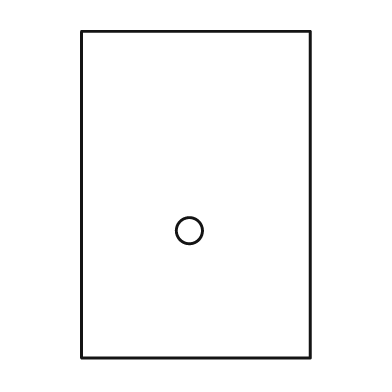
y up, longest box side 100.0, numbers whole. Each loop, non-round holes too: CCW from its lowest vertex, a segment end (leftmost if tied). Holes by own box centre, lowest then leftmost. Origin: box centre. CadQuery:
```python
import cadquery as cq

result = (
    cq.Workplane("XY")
    .moveTo(-35.0, -50.0)
    .lineTo(35.0, -50.0)
    .lineTo(35.0, 50.0)
    .lineTo(-35.0, 50.0)
    .close()
    .moveTo(-2.0, -11.0)
    .circle(4.0)
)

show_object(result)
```